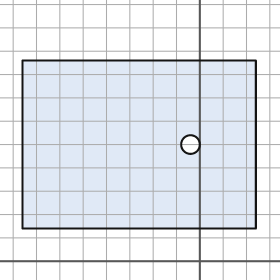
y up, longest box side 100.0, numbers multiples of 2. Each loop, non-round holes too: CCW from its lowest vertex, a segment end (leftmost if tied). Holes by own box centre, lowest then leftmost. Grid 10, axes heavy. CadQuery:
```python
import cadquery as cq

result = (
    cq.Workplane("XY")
    .moveTo(-76.0, 14.0)
    .lineTo(24.0, 14.0)
    .lineTo(24.0, 86.0)
    .lineTo(-76.0, 86.0)
    .close()
    .moveTo(-4.0, 50.0)
    .circle(4.0)
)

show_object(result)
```